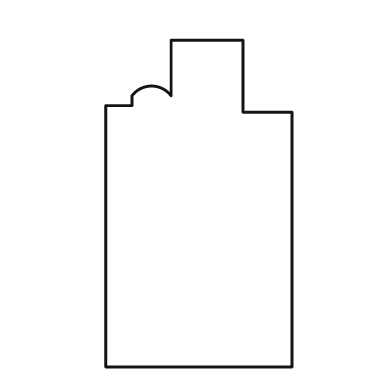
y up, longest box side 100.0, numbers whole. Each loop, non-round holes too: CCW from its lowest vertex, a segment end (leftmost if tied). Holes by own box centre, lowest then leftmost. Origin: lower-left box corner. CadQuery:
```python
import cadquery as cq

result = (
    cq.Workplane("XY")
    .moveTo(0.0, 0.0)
    .lineTo(57.0, 0.0)
    .lineTo(57.0, 78.0)
    .lineTo(42.0, 78.0)
    .lineTo(42.0, 100.0)
    .lineTo(20.0, 100.0)
    .lineTo(20.0, 83.0)
    .threePointArc((14.0, 86.0), (8.0, 83.0))
    .lineTo(8.0, 80.0)
    .lineTo(0.0, 80.0)
    .close()
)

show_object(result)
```